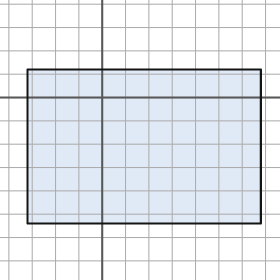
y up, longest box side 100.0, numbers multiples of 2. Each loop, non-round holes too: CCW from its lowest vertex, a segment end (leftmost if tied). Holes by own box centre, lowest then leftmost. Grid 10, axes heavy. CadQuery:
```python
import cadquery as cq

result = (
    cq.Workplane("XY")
    .moveTo(-32.0, -54.0)
    .lineTo(68.0, -54.0)
    .lineTo(68.0, 12.0)
    .lineTo(-32.0, 12.0)
    .close()
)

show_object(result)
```